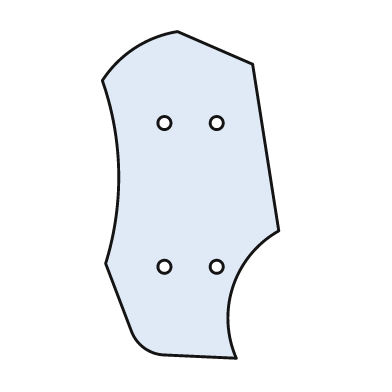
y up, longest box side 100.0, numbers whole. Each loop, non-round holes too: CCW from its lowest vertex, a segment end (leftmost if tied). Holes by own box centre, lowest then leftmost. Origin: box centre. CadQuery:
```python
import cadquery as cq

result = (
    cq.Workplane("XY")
    .moveTo(14.0, -50.0)
    .threePointArc((13.0, -28.0), (27.0, -11.0))
    .lineTo(19.0, 40.0)
    .lineTo(-4.0, 50.0)
    .threePointArc((-17.0, 45.0), (-27.0, 35.0))
    .threePointArc((-22.0, 7.0), (-26.0, -21.0))
    .lineTo(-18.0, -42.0)
    .threePointArc((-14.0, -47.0), (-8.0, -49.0))
    .close()
    .moveTo(-8.0, -22.0)
    .circle(2.0)
    .moveTo(8.0, -22.0)
    .circle(2.0)
    .moveTo(-8.0, 22.0)
    .circle(2.0)
    .moveTo(8.0, 22.0)
    .circle(2.0)
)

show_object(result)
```